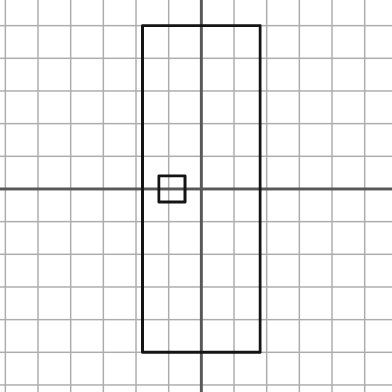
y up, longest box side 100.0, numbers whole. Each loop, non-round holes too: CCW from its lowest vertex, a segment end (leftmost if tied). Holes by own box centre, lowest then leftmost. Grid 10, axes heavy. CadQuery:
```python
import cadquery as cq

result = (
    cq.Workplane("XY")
    .moveTo(-18.0, -50.0)
    .lineTo(18.0, -50.0)
    .lineTo(18.0, 50.0)
    .lineTo(-18.0, 50.0)
    .close()
    .moveTo(-13.0, -4.0)
    .lineTo(-5.0, -4.0)
    .lineTo(-5.0, 4.0)
    .lineTo(-13.0, 4.0)
    .close()
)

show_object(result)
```